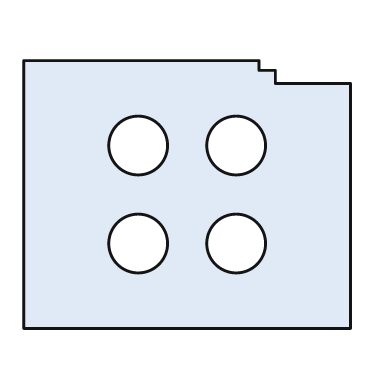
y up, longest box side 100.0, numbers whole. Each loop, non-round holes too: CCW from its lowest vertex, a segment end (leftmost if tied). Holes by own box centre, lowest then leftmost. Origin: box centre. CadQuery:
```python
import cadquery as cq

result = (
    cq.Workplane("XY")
    .moveTo(-50.0, -41.0)
    .lineTo(50.0, -41.0)
    .lineTo(50.0, 34.0)
    .lineTo(27.0, 34.0)
    .lineTo(27.0, 38.0)
    .lineTo(22.0, 38.0)
    .lineTo(22.0, 41.0)
    .lineTo(-50.0, 41.0)
    .close()
    .moveTo(-15.0, -15.0)
    .circle(9.0)
    .moveTo(15.0, -15.0)
    .circle(9.0)
    .moveTo(-15.0, 15.0)
    .circle(9.0)
    .moveTo(15.0, 15.0)
    .circle(9.0)
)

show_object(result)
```